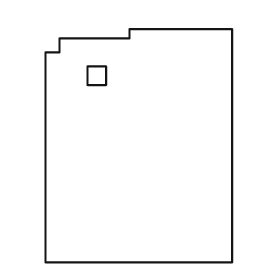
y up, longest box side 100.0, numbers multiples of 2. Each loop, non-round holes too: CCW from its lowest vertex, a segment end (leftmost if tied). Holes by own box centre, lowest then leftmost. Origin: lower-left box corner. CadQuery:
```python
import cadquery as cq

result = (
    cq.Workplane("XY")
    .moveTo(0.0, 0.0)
    .lineTo(80.0, 0.0)
    .lineTo(80.0, 100.0)
    .lineTo(36.0, 100.0)
    .lineTo(36.0, 96.0)
    .lineTo(6.0, 96.0)
    .lineTo(6.0, 90.0)
    .lineTo(0.0, 90.0)
    .close()
    .moveTo(18.0, 76.0)
    .lineTo(26.0, 76.0)
    .lineTo(26.0, 84.0)
    .lineTo(18.0, 84.0)
    .close()
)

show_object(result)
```